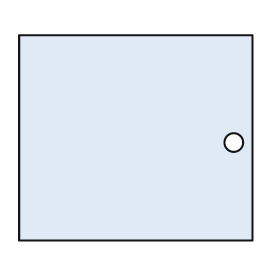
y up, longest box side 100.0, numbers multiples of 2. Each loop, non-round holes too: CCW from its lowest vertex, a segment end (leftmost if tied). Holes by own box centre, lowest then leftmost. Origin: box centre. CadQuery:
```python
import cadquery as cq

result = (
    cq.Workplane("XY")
    .moveTo(-50.0, -44.0)
    .lineTo(50.0, -44.0)
    .lineTo(50.0, 44.0)
    .lineTo(-50.0, 44.0)
    .close()
    .moveTo(42.0, -2.0)
    .circle(4.0)
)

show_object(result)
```